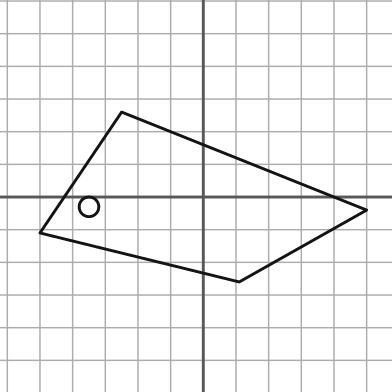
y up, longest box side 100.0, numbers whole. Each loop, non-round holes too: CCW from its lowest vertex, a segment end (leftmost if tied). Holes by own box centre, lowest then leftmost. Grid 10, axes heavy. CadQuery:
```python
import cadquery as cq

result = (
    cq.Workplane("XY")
    .moveTo(11.0, -26.0)
    .lineTo(50.0, -4.0)
    .lineTo(-25.0, 26.0)
    .lineTo(-50.0, -11.0)
    .close()
    .moveTo(-35.0, -3.0)
    .circle(3.0)
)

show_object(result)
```